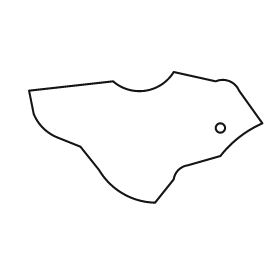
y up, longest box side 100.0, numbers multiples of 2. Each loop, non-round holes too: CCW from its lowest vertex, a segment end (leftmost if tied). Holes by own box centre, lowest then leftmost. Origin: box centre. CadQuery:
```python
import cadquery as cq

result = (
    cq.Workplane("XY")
    .moveTo(4.0, -28.0)
    .lineTo(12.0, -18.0)
    .threePointArc((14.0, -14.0), (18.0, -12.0))
    .lineTo(32.0, -8.0)
    .threePointArc((40.0, 0.0), (50.0, 6.0))
    .lineTo(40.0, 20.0)
    .threePointArc((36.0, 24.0), (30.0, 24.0))
    .lineTo(12.0, 28.0)
    .threePointArc((0.0, 20.0), (-14.0, 24.0))
    .lineTo(-50.0, 20.0)
    .lineTo(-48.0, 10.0)
    .threePointArc((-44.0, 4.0), (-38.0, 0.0))
    .lineTo(-28.0, -4.0)
    .lineTo(-20.0, -14.0)
    .threePointArc((-10.0, -24.0), (4.0, -28.0))
    .close()
    .moveTo(32.0, 4.0)
    .circle(2.0)
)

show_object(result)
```